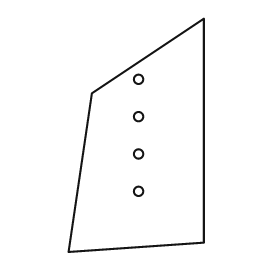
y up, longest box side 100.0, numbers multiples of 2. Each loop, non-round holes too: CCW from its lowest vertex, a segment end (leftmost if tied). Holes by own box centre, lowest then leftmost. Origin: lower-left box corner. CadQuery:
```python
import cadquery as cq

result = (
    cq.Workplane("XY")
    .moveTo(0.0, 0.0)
    .lineTo(58.0, 4.0)
    .lineTo(58.0, 100.0)
    .lineTo(10.0, 68.0)
    .close()
    .moveTo(30.0, 26.0)
    .circle(2.0)
    .moveTo(30.0, 42.0)
    .circle(2.0)
    .moveTo(30.0, 58.0)
    .circle(2.0)
    .moveTo(30.0, 74.0)
    .circle(2.0)
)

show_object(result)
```